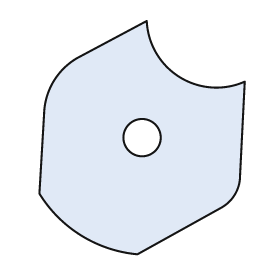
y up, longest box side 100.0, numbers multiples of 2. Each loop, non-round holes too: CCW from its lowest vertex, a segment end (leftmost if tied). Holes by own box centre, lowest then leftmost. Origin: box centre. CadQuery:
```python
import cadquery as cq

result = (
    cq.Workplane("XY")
    .moveTo(-2.0, -50.0)
    .lineTo(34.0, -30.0)
    .threePointArc((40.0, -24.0), (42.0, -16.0))
    .lineTo(44.0, 24.0)
    .threePointArc((16.0, 26.0), (2.0, 50.0))
    .lineTo(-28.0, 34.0)
    .threePointArc((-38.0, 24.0), (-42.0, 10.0))
    .lineTo(-44.0, -24.0)
    .threePointArc((-26.0, -42.0), (-2.0, -50.0))
    .close()
    .moveTo(0.0, 0.0)
    .circle(8.0)
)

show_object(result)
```